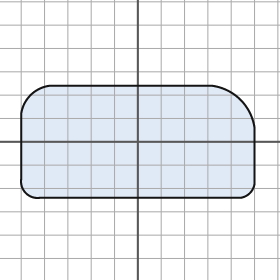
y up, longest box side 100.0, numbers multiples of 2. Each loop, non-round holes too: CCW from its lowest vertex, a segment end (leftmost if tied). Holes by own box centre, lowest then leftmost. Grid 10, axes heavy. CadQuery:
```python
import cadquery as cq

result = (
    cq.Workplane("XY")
    .moveTo(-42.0, -24.0)
    .lineTo(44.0, -24.0)
    .threePointArc((48.0, -22.0), (50.0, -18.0))
    .lineTo(50.0, 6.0)
    .threePointArc((44.0, 18.0), (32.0, 24.0))
    .lineTo(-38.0, 24.0)
    .threePointArc((-46.0, 20.0), (-50.0, 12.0))
    .lineTo(-50.0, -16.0)
    .threePointArc((-48.0, -22.0), (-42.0, -24.0))
    .close()
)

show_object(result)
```